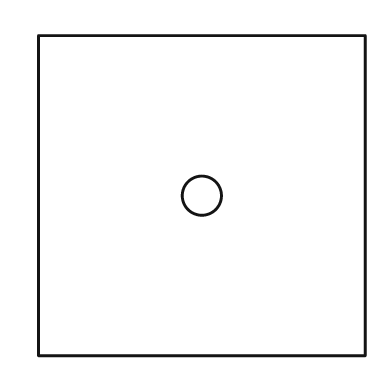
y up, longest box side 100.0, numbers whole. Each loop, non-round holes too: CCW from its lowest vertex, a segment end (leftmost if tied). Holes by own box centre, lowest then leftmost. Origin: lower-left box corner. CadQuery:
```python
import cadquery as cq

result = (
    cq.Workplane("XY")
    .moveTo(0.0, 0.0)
    .lineTo(100.0, 0.0)
    .lineTo(100.0, 98.0)
    .lineTo(0.0, 98.0)
    .close()
    .moveTo(50.0, 49.0)
    .circle(6.0)
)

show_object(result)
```